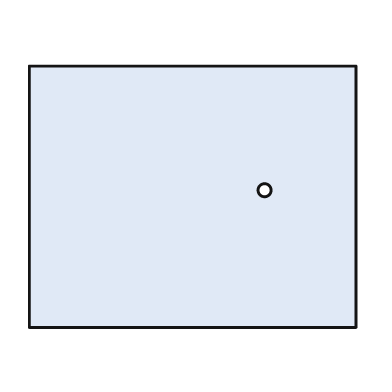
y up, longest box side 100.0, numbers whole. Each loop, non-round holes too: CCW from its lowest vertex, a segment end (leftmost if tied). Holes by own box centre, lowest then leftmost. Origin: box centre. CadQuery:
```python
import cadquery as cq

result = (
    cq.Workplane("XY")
    .moveTo(-50.0, -40.0)
    .lineTo(50.0, -40.0)
    .lineTo(50.0, 40.0)
    .lineTo(-50.0, 40.0)
    .close()
    .moveTo(22.0, 2.0)
    .circle(2.0)
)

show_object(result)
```